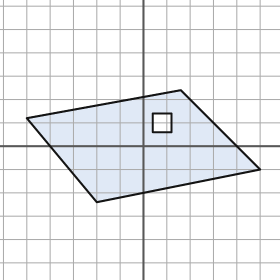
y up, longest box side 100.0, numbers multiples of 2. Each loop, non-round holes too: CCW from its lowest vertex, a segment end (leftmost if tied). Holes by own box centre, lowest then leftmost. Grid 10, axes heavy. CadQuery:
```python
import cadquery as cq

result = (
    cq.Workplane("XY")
    .moveTo(-20.0, -24.0)
    .lineTo(50.0, -10.0)
    .lineTo(16.0, 24.0)
    .lineTo(-50.0, 12.0)
    .close()
    .moveTo(4.0, 6.0)
    .lineTo(12.0, 6.0)
    .lineTo(12.0, 14.0)
    .lineTo(4.0, 14.0)
    .close()
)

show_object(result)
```